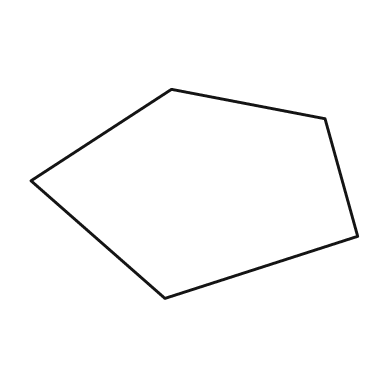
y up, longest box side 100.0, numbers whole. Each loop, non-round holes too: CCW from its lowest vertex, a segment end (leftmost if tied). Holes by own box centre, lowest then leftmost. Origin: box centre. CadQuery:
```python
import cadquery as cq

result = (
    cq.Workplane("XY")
    .moveTo(-9.0, -32.0)
    .lineTo(50.0, -13.0)
    .lineTo(40.0, 23.0)
    .lineTo(-7.0, 32.0)
    .lineTo(-50.0, 4.0)
    .close()
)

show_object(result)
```